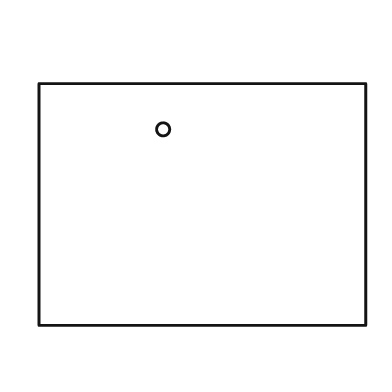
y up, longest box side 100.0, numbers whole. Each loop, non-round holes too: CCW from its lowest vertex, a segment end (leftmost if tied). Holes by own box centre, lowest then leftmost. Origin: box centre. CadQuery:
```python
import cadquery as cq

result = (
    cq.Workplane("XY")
    .moveTo(-50.0, -37.0)
    .lineTo(50.0, -37.0)
    .lineTo(50.0, 37.0)
    .lineTo(-50.0, 37.0)
    .close()
    .moveTo(-12.0, 23.0)
    .circle(2.0)
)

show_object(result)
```